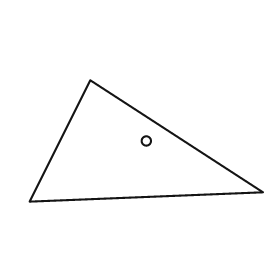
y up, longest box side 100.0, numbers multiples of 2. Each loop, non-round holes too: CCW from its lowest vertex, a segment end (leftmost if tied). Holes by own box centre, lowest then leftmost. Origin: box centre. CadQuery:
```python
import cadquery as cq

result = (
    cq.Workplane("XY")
    .moveTo(-50.0, -26.0)
    .lineTo(50.0, -22.0)
    .lineTo(-24.0, 26.0)
    .close()
    .moveTo(0.0, 0.0)
    .circle(2.0)
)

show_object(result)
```